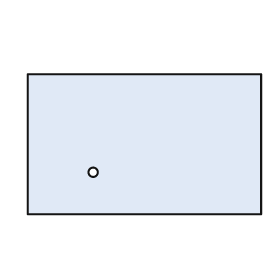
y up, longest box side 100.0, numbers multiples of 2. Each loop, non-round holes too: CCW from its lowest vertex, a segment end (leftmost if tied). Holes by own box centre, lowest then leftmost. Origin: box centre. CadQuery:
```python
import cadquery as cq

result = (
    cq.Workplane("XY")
    .moveTo(-50.0, -30.0)
    .lineTo(50.0, -30.0)
    .lineTo(50.0, 30.0)
    .lineTo(-50.0, 30.0)
    .close()
    .moveTo(-22.0, -12.0)
    .circle(2.0)
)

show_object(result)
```